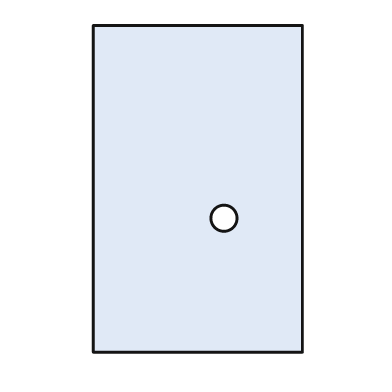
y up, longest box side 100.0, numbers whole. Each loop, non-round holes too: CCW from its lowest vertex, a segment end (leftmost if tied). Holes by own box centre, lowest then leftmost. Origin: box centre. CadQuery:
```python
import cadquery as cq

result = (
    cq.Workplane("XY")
    .moveTo(-32.0, -50.0)
    .lineTo(32.0, -50.0)
    .lineTo(32.0, 50.0)
    .lineTo(-32.0, 50.0)
    .close()
    .moveTo(8.0, -9.0)
    .circle(4.0)
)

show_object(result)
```